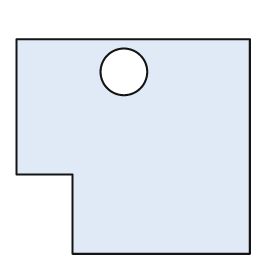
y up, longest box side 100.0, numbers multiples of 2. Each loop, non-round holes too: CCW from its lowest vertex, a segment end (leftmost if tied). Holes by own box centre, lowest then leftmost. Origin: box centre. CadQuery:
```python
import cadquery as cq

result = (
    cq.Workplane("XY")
    .moveTo(-26.0, -46.0)
    .lineTo(50.0, -46.0)
    .lineTo(50.0, 46.0)
    .lineTo(-50.0, 46.0)
    .lineTo(-50.0, -12.0)
    .lineTo(-26.0, -12.0)
    .close()
    .moveTo(-4.0, 32.0)
    .circle(10.0)
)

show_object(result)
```